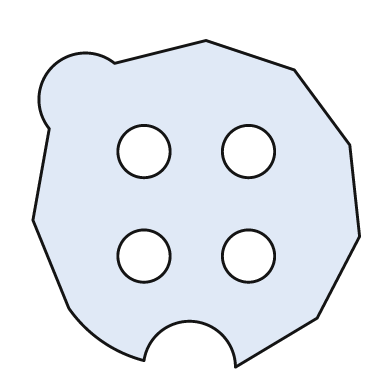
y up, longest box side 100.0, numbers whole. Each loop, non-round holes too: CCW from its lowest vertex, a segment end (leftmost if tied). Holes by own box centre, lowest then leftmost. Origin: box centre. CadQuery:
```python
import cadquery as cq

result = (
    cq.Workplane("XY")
    .moveTo(12.0, -50.0)
    .lineTo(37.0, -35.0)
    .lineTo(50.0, -10.0)
    .lineTo(47.0, 18.0)
    .lineTo(30.0, 41.0)
    .lineTo(3.0, 50.0)
    .lineTo(-25.0, 43.0)
    .threePointArc((-44.0, 42.0), (-45.0, 23.0))
    .lineTo(-50.0, -5.0)
    .lineTo(-39.0, -32.0)
    .threePointArc((-29.0, -42.0), (-16.0, -48.0))
    .threePointArc((-1.0, -36.0), (12.0, -50.0))
    .close()
    .moveTo(-16.0, -16.0)
    .circle(8.0)
    .moveTo(16.0, -16.0)
    .circle(8.0)
    .moveTo(-16.0, 16.0)
    .circle(8.0)
    .moveTo(16.0, 16.0)
    .circle(8.0)
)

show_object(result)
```